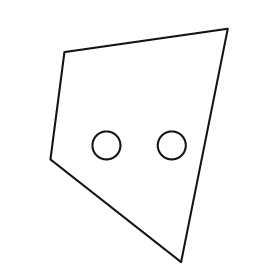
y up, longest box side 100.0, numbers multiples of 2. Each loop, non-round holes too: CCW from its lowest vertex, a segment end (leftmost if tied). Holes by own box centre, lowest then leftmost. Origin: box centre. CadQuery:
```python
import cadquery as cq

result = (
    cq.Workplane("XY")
    .moveTo(18.0, -50.0)
    .lineTo(38.0, 50.0)
    .lineTo(-32.0, 40.0)
    .lineTo(-38.0, -6.0)
    .close()
    .moveTo(-14.0, 0.0)
    .circle(6.0)
    .moveTo(14.0, 0.0)
    .circle(6.0)
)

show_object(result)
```